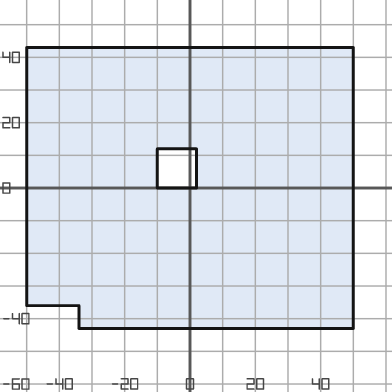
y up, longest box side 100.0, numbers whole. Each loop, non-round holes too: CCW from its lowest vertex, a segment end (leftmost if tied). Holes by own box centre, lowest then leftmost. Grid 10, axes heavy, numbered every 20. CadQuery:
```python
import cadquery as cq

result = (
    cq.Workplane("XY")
    .moveTo(-34.0, -43.0)
    .lineTo(50.0, -43.0)
    .lineTo(50.0, 43.0)
    .lineTo(-50.0, 43.0)
    .lineTo(-50.0, -36.0)
    .lineTo(-34.0, -36.0)
    .close()
    .moveTo(-10.0, 0.0)
    .lineTo(2.0, 0.0)
    .lineTo(2.0, 12.0)
    .lineTo(-10.0, 12.0)
    .close()
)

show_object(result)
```